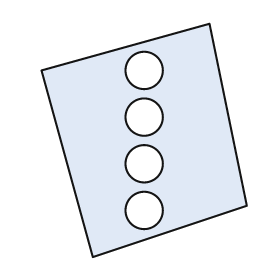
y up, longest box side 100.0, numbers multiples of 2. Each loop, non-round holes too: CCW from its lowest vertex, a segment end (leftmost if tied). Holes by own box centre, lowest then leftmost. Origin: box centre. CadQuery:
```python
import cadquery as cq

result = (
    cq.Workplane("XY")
    .moveTo(-22.0, -50.0)
    .lineTo(44.0, -28.0)
    .lineTo(28.0, 50.0)
    .lineTo(-44.0, 30.0)
    .close()
    .moveTo(0.0, -30.0)
    .circle(8.0)
    .moveTo(0.0, -10.0)
    .circle(8.0)
    .moveTo(0.0, 10.0)
    .circle(8.0)
    .moveTo(0.0, 30.0)
    .circle(8.0)
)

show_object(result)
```